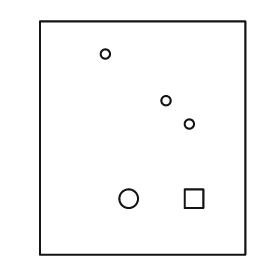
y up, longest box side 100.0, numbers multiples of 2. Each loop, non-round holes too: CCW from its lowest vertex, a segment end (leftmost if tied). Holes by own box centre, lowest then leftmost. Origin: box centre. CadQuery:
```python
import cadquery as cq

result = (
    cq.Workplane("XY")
    .moveTo(-44.0, -50.0)
    .lineTo(44.0, -50.0)
    .lineTo(44.0, 50.0)
    .lineTo(-44.0, 50.0)
    .close()
    .moveTo(-6.0, -26.0)
    .circle(4.0)
    .moveTo(18.0, -30.0)
    .lineTo(26.0, -30.0)
    .lineTo(26.0, -22.0)
    .lineTo(18.0, -22.0)
    .close()
    .moveTo(20.0, 6.0)
    .circle(2.0)
    .moveTo(10.0, 16.0)
    .circle(2.0)
    .moveTo(-16.0, 36.0)
    .circle(2.0)
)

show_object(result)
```